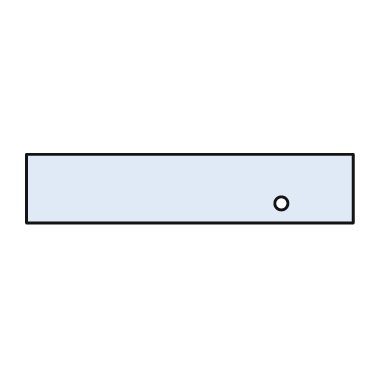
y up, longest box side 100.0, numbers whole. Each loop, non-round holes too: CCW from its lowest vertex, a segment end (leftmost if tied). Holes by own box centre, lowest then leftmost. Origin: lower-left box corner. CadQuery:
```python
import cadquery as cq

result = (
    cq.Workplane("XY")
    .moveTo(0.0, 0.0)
    .lineTo(100.0, 0.0)
    .lineTo(100.0, 21.0)
    .lineTo(0.0, 21.0)
    .close()
    .moveTo(78.0, 6.0)
    .circle(2.0)
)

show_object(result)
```